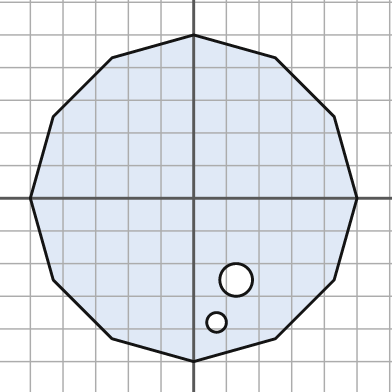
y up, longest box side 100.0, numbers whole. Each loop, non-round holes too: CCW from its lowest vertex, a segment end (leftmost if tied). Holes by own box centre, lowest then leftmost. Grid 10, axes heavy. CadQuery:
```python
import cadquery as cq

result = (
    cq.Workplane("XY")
    .moveTo(0.0, -50.0)
    .lineTo(25.0, -43.0)
    .lineTo(43.0, -25.0)
    .lineTo(50.0, 0.0)
    .lineTo(43.0, 25.0)
    .lineTo(25.0, 43.0)
    .lineTo(0.0, 50.0)
    .lineTo(-25.0, 43.0)
    .lineTo(-43.0, 25.0)
    .lineTo(-50.0, 0.0)
    .lineTo(-43.0, -25.0)
    .lineTo(-25.0, -43.0)
    .close()
    .moveTo(7.0, -38.0)
    .circle(3.0)
    .moveTo(13.0, -25.0)
    .circle(5.0)
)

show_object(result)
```